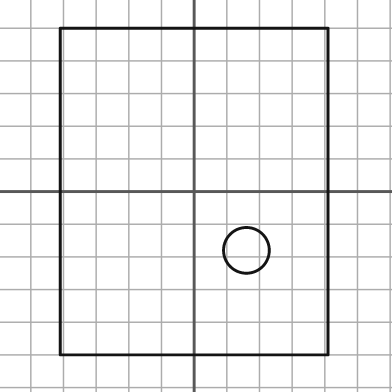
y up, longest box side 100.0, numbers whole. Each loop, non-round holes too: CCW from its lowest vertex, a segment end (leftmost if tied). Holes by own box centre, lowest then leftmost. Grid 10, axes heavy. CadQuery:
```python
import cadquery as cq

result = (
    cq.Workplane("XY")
    .moveTo(-41.0, -50.0)
    .lineTo(41.0, -50.0)
    .lineTo(41.0, 50.0)
    .lineTo(-41.0, 50.0)
    .close()
    .moveTo(16.0, -18.0)
    .circle(7.0)
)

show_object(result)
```